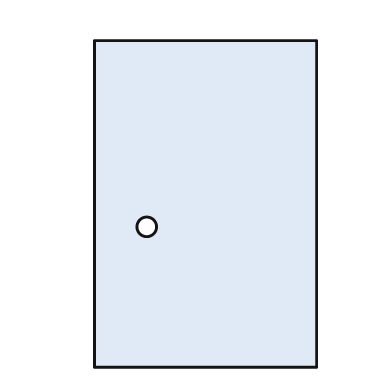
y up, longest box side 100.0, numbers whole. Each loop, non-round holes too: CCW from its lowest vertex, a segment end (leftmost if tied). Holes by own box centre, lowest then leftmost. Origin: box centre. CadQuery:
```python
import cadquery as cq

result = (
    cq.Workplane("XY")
    .moveTo(-34.0, -50.0)
    .lineTo(34.0, -50.0)
    .lineTo(34.0, 50.0)
    .lineTo(-34.0, 50.0)
    .close()
    .moveTo(-18.0, -7.0)
    .circle(3.0)
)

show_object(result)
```